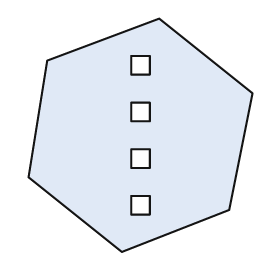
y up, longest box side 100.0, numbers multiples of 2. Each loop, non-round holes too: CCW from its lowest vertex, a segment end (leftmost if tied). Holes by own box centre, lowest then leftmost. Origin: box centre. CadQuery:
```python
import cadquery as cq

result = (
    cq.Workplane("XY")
    .moveTo(-8.0, -50.0)
    .lineTo(38.0, -32.0)
    .lineTo(48.0, 18.0)
    .lineTo(8.0, 50.0)
    .lineTo(-40.0, 32.0)
    .lineTo(-48.0, -18.0)
    .close()
    .moveTo(-4.0, -34.0)
    .lineTo(4.0, -34.0)
    .lineTo(4.0, -26.0)
    .lineTo(-4.0, -26.0)
    .close()
    .moveTo(-4.0, -14.0)
    .lineTo(4.0, -14.0)
    .lineTo(4.0, -6.0)
    .lineTo(-4.0, -6.0)
    .close()
    .moveTo(-4.0, 6.0)
    .lineTo(4.0, 6.0)
    .lineTo(4.0, 14.0)
    .lineTo(-4.0, 14.0)
    .close()
    .moveTo(-4.0, 26.0)
    .lineTo(4.0, 26.0)
    .lineTo(4.0, 34.0)
    .lineTo(-4.0, 34.0)
    .close()
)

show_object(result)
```